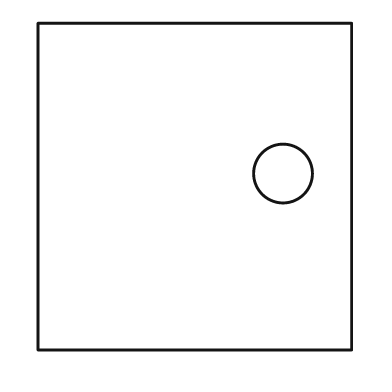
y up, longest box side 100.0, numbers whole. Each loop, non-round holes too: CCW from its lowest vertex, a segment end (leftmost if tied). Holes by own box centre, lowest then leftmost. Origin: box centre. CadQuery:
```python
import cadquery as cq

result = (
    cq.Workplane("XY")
    .moveTo(-48.0, -50.0)
    .lineTo(48.0, -50.0)
    .lineTo(48.0, 50.0)
    .lineTo(-48.0, 50.0)
    .close()
    .moveTo(27.0, 4.0)
    .circle(9.0)
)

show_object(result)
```